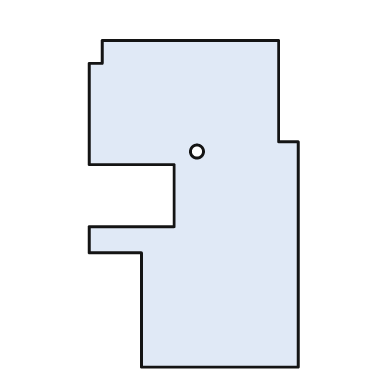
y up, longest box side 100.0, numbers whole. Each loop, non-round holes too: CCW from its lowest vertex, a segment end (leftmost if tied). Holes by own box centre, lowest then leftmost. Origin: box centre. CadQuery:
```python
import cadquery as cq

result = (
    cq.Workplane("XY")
    .moveTo(-16.0, -50.0)
    .lineTo(32.0, -50.0)
    .lineTo(32.0, 19.0)
    .lineTo(26.0, 19.0)
    .lineTo(26.0, 50.0)
    .lineTo(-28.0, 50.0)
    .lineTo(-28.0, 43.0)
    .lineTo(-32.0, 43.0)
    .lineTo(-32.0, 12.0)
    .lineTo(-6.0, 12.0)
    .lineTo(-6.0, -7.0)
    .lineTo(-32.0, -7.0)
    .lineTo(-32.0, -15.0)
    .lineTo(-16.0, -15.0)
    .close()
    .moveTo(1.0, 16.0)
    .circle(2.0)
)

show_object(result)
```